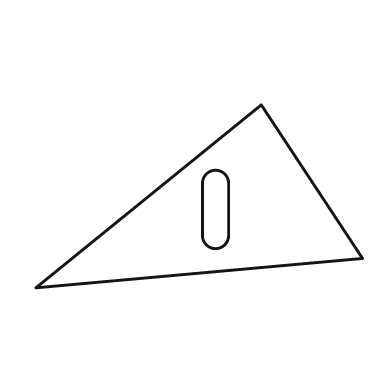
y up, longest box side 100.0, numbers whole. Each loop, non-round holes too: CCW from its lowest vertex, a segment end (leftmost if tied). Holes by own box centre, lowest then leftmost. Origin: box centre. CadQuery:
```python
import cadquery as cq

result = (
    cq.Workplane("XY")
    .moveTo(-50.0, -28.0)
    .lineTo(50.0, -19.0)
    .lineTo(19.0, 28.0)
    .close()
    .moveTo(1.0, -12.0)
    .threePointArc((5.0, -16.0), (9.0, -12.0))
    .lineTo(9.0, 4.0)
    .threePointArc((5.0, 8.0), (1.0, 4.0))
    .close()
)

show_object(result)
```